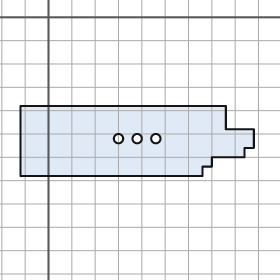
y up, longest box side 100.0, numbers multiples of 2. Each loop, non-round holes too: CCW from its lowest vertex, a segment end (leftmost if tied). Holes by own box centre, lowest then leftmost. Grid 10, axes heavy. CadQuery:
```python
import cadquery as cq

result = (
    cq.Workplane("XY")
    .moveTo(-12.0, -68.0)
    .lineTo(66.0, -68.0)
    .lineTo(66.0, -64.0)
    .lineTo(70.0, -64.0)
    .lineTo(70.0, -60.0)
    .lineTo(84.0, -60.0)
    .lineTo(84.0, -56.0)
    .lineTo(88.0, -56.0)
    .lineTo(88.0, -48.0)
    .lineTo(76.0, -48.0)
    .lineTo(76.0, -38.0)
    .lineTo(-12.0, -38.0)
    .close()
    .moveTo(30.0, -52.0)
    .circle(2.0)
    .moveTo(38.0, -52.0)
    .circle(2.0)
    .moveTo(46.0, -52.0)
    .circle(2.0)
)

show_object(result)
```